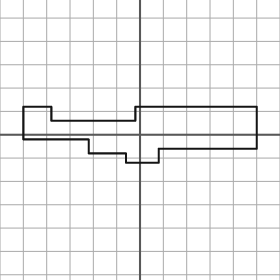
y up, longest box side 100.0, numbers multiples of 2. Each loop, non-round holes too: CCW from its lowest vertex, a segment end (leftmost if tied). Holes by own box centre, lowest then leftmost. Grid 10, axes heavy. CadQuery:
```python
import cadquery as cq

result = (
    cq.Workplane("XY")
    .moveTo(-6.0, -12.0)
    .lineTo(8.0, -12.0)
    .lineTo(8.0, -6.0)
    .lineTo(50.0, -6.0)
    .lineTo(50.0, 12.0)
    .lineTo(-2.0, 12.0)
    .lineTo(-2.0, 6.0)
    .lineTo(-38.0, 6.0)
    .lineTo(-38.0, 12.0)
    .lineTo(-50.0, 12.0)
    .lineTo(-50.0, -2.0)
    .lineTo(-22.0, -2.0)
    .lineTo(-22.0, -8.0)
    .lineTo(-6.0, -8.0)
    .close()
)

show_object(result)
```